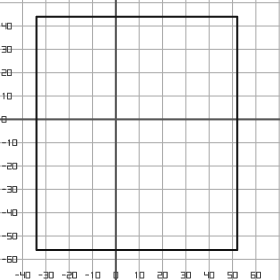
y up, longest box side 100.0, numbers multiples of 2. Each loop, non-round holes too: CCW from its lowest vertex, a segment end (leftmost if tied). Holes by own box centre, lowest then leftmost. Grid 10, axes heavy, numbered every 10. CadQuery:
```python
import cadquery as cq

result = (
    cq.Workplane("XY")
    .moveTo(-34.0, -56.0)
    .lineTo(52.0, -56.0)
    .lineTo(52.0, 44.0)
    .lineTo(-34.0, 44.0)
    .close()
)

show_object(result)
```